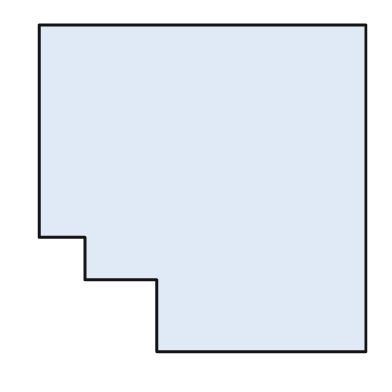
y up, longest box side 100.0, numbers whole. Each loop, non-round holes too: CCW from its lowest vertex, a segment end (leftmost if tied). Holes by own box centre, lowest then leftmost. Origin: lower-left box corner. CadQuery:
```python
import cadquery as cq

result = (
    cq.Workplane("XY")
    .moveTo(36.0, 0.0)
    .lineTo(100.0, 0.0)
    .lineTo(100.0, 100.0)
    .lineTo(0.0, 100.0)
    .lineTo(0.0, 35.0)
    .lineTo(14.0, 35.0)
    .lineTo(14.0, 22.0)
    .lineTo(36.0, 22.0)
    .close()
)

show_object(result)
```